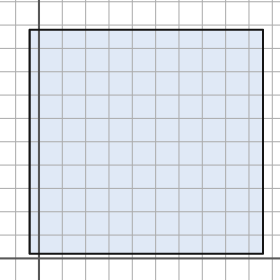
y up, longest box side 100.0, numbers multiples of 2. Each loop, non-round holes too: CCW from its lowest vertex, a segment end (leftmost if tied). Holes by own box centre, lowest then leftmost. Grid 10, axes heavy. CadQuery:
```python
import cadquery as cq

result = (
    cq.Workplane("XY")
    .moveTo(-4.0, 2.0)
    .lineTo(96.0, 2.0)
    .lineTo(96.0, 98.0)
    .lineTo(-4.0, 98.0)
    .close()
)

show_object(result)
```